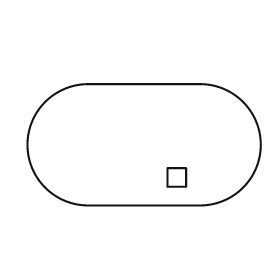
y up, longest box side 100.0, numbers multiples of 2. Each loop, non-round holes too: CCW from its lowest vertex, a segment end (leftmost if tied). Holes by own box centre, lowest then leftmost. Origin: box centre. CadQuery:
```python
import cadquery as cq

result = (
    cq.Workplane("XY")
    .moveTo(-24.0, -26.0)
    .lineTo(24.0, -26.0)
    .threePointArc((50.0, 0.0), (24.0, 26.0))
    .lineTo(-24.0, 26.0)
    .threePointArc((-50.0, 0.0), (-24.0, -26.0))
    .close()
    .moveTo(10.0, -18.0)
    .lineTo(18.0, -18.0)
    .lineTo(18.0, -10.0)
    .lineTo(10.0, -10.0)
    .close()
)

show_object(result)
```